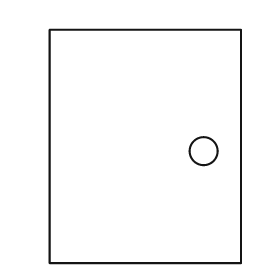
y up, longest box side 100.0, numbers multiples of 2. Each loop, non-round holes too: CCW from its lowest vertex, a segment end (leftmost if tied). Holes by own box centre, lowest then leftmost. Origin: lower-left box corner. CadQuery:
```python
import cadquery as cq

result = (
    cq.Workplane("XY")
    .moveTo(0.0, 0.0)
    .lineTo(82.0, 0.0)
    .lineTo(82.0, 100.0)
    .lineTo(0.0, 100.0)
    .close()
    .moveTo(66.0, 48.0)
    .circle(6.0)
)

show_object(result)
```